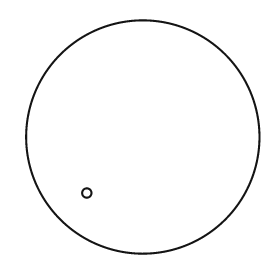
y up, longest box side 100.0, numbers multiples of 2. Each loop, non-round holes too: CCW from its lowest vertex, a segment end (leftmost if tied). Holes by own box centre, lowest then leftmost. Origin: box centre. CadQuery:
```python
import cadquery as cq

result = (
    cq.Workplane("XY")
    .moveTo(0.0, 0.0)
    .circle(50.0)
    .moveTo(-24.0, -24.0)
    .circle(2.0)
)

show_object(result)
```